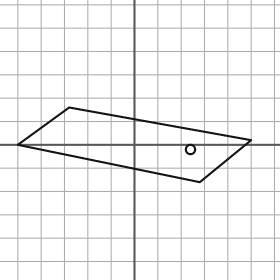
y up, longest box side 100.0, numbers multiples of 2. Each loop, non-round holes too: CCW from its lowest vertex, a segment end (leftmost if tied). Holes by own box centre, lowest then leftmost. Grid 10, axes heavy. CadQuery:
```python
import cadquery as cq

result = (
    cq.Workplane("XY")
    .moveTo(28.0, -16.0)
    .lineTo(50.0, 2.0)
    .lineTo(-28.0, 16.0)
    .lineTo(-50.0, 0.0)
    .close()
    .moveTo(24.0, -2.0)
    .circle(2.0)
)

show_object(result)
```